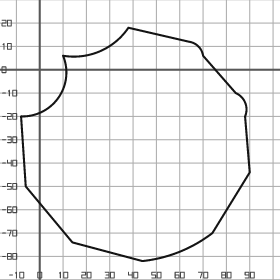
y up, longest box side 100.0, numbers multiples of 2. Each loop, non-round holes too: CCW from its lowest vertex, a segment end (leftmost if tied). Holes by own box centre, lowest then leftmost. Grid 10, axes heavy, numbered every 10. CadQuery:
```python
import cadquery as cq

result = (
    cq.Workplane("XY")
    .moveTo(44.0, -82.0)
    .threePointArc((60.0, -78.0), (74.0, -70.0))
    .lineTo(90.0, -44.0)
    .lineTo(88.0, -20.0)
    .threePointArc((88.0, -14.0), (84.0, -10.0))
    .lineTo(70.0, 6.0)
    .threePointArc((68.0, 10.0), (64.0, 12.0))
    .lineTo(38.0, 18.0)
    .threePointArc((26.0, 8.0), (10.0, 6.0))
    .threePointArc((8.0, -12.0), (-8.0, -20.0))
    .lineTo(-6.0, -50.0)
    .lineTo(14.0, -74.0)
    .close()
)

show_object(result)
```